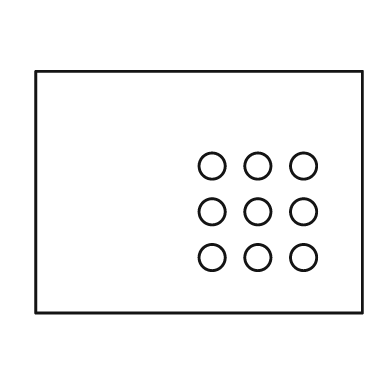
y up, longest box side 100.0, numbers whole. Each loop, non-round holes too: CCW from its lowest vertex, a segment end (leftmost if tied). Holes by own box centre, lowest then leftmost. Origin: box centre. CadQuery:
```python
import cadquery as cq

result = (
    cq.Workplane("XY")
    .moveTo(-50.0, -37.0)
    .lineTo(50.0, -37.0)
    .lineTo(50.0, 37.0)
    .lineTo(-50.0, 37.0)
    .close()
    .moveTo(4.0, -20.0)
    .circle(4.0)
    .moveTo(18.0, -20.0)
    .circle(4.0)
    .moveTo(32.0, -20.0)
    .circle(4.0)
    .moveTo(4.0, -6.0)
    .circle(4.0)
    .moveTo(18.0, -6.0)
    .circle(4.0)
    .moveTo(32.0, -6.0)
    .circle(4.0)
    .moveTo(4.0, 8.0)
    .circle(4.0)
    .moveTo(18.0, 8.0)
    .circle(4.0)
    .moveTo(32.0, 8.0)
    .circle(4.0)
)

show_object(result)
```